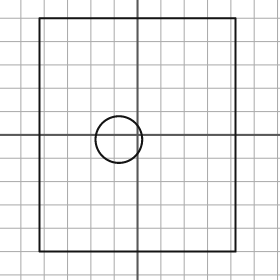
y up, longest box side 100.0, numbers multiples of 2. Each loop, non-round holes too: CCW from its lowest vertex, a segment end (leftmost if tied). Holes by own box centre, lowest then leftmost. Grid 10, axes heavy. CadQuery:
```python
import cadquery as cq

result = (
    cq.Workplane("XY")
    .moveTo(-42.0, -50.0)
    .lineTo(42.0, -50.0)
    .lineTo(42.0, 50.0)
    .lineTo(-42.0, 50.0)
    .close()
    .moveTo(-8.0, -2.0)
    .circle(10.0)
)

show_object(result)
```